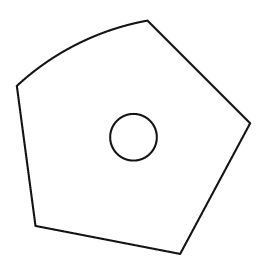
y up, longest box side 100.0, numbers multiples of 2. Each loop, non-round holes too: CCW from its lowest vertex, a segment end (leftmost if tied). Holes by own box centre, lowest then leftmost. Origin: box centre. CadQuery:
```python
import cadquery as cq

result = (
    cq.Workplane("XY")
    .moveTo(20.0, -50.0)
    .lineTo(50.0, 6.0)
    .lineTo(6.0, 50.0)
    .threePointArc((-24.0, 40.0), (-50.0, 22.0))
    .lineTo(-42.0, -38.0)
    .close()
    .moveTo(0.0, 0.0)
    .circle(10.0)
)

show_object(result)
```